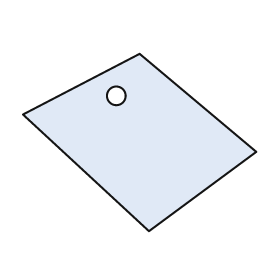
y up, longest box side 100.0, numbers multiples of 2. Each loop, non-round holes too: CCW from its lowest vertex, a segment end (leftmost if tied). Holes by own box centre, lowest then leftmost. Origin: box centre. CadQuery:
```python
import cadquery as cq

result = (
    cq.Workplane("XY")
    .moveTo(4.0, -38.0)
    .lineTo(50.0, -4.0)
    .lineTo(0.0, 38.0)
    .lineTo(-50.0, 12.0)
    .close()
    .moveTo(-10.0, 20.0)
    .circle(4.0)
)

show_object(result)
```